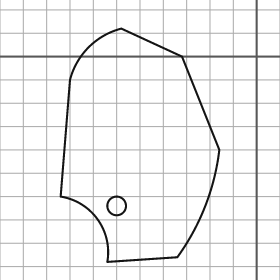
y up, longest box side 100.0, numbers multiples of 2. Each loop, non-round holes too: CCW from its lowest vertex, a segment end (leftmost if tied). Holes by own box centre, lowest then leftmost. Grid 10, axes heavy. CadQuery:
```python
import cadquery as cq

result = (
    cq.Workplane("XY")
    .moveTo(-64.0, -88.0)
    .lineTo(-34.0, -86.0)
    .threePointArc((-22.0, -64.0), (-16.0, -40.0))
    .lineTo(-32.0, 0.0)
    .lineTo(-58.0, 12.0)
    .threePointArc((-72.0, 4.0), (-80.0, -10.0))
    .lineTo(-84.0, -60.0)
    .threePointArc((-68.0, -70.0), (-64.0, -88.0))
    .close()
    .moveTo(-60.0, -64.0)
    .circle(4.0)
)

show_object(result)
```